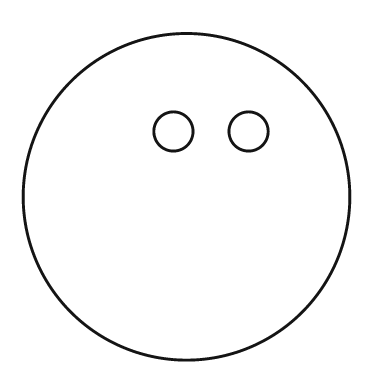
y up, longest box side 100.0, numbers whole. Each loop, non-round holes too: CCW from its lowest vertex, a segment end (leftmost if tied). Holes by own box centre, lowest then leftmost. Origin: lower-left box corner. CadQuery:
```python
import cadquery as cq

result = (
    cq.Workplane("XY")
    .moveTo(50.0, 50.0)
    .circle(50.0)
    .moveTo(46.0, 70.0)
    .circle(6.0)
    .moveTo(69.0, 70.0)
    .circle(6.0)
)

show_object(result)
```